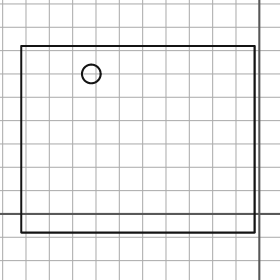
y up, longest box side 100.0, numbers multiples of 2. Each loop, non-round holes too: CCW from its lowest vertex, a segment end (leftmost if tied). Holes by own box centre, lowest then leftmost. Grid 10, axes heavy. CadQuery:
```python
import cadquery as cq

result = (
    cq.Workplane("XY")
    .moveTo(-102.0, -8.0)
    .lineTo(-2.0, -8.0)
    .lineTo(-2.0, 72.0)
    .lineTo(-102.0, 72.0)
    .close()
    .moveTo(-72.0, 60.0)
    .circle(4.0)
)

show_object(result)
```